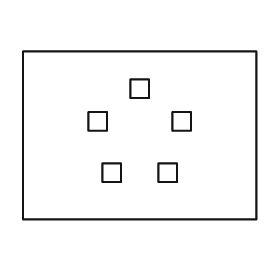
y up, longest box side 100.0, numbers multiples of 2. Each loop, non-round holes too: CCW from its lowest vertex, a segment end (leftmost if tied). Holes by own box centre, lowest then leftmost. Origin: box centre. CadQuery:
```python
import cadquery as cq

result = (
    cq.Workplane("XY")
    .moveTo(-50.0, -36.0)
    .lineTo(50.0, -36.0)
    .lineTo(50.0, 36.0)
    .lineTo(-50.0, 36.0)
    .close()
    .moveTo(-16.0, -20.0)
    .lineTo(-8.0, -20.0)
    .lineTo(-8.0, -12.0)
    .lineTo(-16.0, -12.0)
    .close()
    .moveTo(8.0, -20.0)
    .lineTo(16.0, -20.0)
    .lineTo(16.0, -12.0)
    .lineTo(8.0, -12.0)
    .close()
    .moveTo(-22.0, 2.0)
    .lineTo(-14.0, 2.0)
    .lineTo(-14.0, 10.0)
    .lineTo(-22.0, 10.0)
    .close()
    .moveTo(14.0, 2.0)
    .lineTo(22.0, 2.0)
    .lineTo(22.0, 10.0)
    .lineTo(14.0, 10.0)
    .close()
    .moveTo(-4.0, 16.0)
    .lineTo(4.0, 16.0)
    .lineTo(4.0, 24.0)
    .lineTo(-4.0, 24.0)
    .close()
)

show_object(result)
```